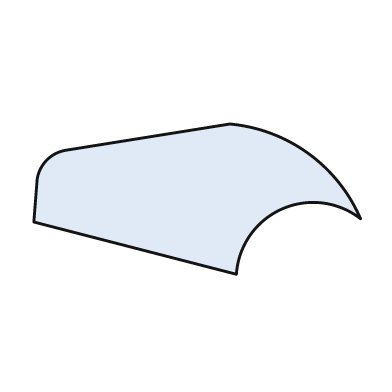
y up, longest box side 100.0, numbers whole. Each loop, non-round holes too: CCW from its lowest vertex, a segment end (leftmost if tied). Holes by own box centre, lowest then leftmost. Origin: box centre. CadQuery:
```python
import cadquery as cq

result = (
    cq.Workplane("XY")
    .moveTo(12.0, -23.0)
    .threePointArc((26.0, -3.0), (50.0, -6.0))
    .threePointArc((34.0, 14.0), (10.0, 23.0))
    .lineTo(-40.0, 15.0)
    .threePointArc((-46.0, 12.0), (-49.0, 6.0))
    .lineTo(-50.0, -7.0)
    .close()
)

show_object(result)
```